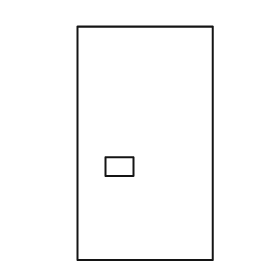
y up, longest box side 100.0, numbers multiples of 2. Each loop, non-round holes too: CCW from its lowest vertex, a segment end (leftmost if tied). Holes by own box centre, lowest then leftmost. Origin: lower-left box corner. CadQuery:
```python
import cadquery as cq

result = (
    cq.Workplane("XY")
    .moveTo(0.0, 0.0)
    .lineTo(58.0, 0.0)
    .lineTo(58.0, 100.0)
    .lineTo(0.0, 100.0)
    .close()
    .moveTo(12.0, 36.0)
    .lineTo(24.0, 36.0)
    .lineTo(24.0, 44.0)
    .lineTo(12.0, 44.0)
    .close()
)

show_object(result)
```